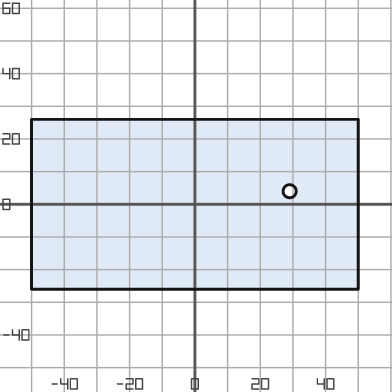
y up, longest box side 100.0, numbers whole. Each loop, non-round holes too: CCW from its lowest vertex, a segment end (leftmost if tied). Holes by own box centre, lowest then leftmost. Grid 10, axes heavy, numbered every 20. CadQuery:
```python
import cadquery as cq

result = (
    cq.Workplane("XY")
    .moveTo(-50.0, -26.0)
    .lineTo(50.0, -26.0)
    .lineTo(50.0, 26.0)
    .lineTo(-50.0, 26.0)
    .close()
    .moveTo(29.0, 4.0)
    .circle(2.0)
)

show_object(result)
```